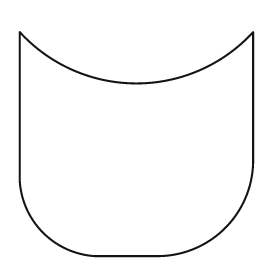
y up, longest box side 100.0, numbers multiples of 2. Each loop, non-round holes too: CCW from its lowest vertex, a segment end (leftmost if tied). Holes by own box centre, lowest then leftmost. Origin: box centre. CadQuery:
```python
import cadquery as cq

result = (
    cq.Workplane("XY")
    .moveTo(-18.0, -48.0)
    .lineTo(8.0, -48.0)
    .threePointArc((38.0, -36.0), (50.0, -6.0))
    .lineTo(50.0, 48.0)
    .threePointArc((0.0, 26.0), (-50.0, 48.0))
    .lineTo(-50.0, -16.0)
    .threePointArc((-40.0, -38.0), (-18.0, -48.0))
    .close()
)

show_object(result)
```